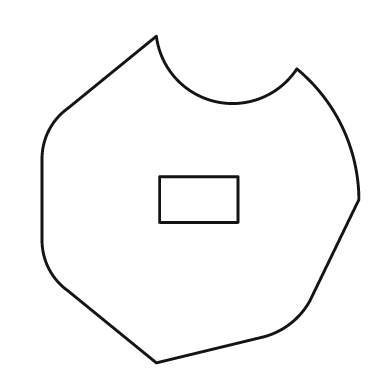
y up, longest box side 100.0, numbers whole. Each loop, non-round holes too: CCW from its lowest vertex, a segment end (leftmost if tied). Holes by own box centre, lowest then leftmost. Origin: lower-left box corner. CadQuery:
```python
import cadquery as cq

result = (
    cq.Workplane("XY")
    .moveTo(35.0, 0.0)
    .lineTo(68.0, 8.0)
    .threePointArc((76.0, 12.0), (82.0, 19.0))
    .lineTo(97.0, 50.0)
    .threePointArc((92.0, 72.0), (78.0, 90.0))
    .threePointArc((53.0, 80.0), (35.0, 100.0))
    .lineTo(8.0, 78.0)
    .threePointArc((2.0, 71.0), (0.0, 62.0))
    .lineTo(0.0, 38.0)
    .threePointArc((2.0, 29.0), (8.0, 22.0))
    .close()
    .moveTo(36.0, 43.0)
    .lineTo(60.0, 43.0)
    .lineTo(60.0, 57.0)
    .lineTo(36.0, 57.0)
    .close()
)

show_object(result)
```